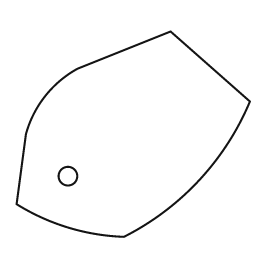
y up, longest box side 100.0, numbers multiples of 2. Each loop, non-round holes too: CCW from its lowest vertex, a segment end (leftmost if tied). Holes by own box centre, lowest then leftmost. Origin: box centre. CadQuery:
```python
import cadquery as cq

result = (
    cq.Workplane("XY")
    .moveTo(-4.0, -44.0)
    .threePointArc((28.0, -20.0), (50.0, 14.0))
    .lineTo(16.0, 44.0)
    .lineTo(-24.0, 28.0)
    .threePointArc((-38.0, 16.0), (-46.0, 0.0))
    .lineTo(-50.0, -30.0)
    .threePointArc((-28.0, -40.0), (-4.0, -44.0))
    .close()
    .moveTo(-28.0, -18.0)
    .circle(4.0)
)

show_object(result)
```